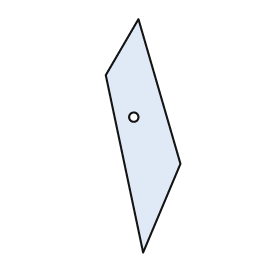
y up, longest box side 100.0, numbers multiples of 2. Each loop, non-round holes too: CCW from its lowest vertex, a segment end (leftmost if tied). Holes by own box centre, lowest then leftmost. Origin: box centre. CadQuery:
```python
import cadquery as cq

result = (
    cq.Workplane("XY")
    .moveTo(0.0, -50.0)
    .lineTo(16.0, -12.0)
    .lineTo(-2.0, 50.0)
    .lineTo(-16.0, 26.0)
    .close()
    .moveTo(-4.0, 8.0)
    .circle(2.0)
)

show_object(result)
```